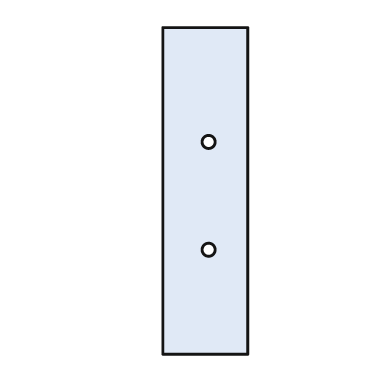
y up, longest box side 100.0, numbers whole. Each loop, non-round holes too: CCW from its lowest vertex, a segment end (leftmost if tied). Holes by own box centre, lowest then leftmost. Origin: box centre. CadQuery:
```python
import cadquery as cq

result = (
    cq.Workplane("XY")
    .moveTo(-13.0, -50.0)
    .lineTo(13.0, -50.0)
    .lineTo(13.0, 50.0)
    .lineTo(-13.0, 50.0)
    .close()
    .moveTo(1.0, -18.0)
    .circle(2.0)
    .moveTo(1.0, 15.0)
    .circle(2.0)
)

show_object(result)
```